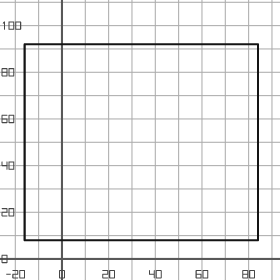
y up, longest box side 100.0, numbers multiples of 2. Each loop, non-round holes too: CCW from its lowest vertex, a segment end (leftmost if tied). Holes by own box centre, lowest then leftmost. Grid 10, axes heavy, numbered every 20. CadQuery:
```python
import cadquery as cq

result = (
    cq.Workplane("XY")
    .moveTo(-16.0, 8.0)
    .lineTo(84.0, 8.0)
    .lineTo(84.0, 92.0)
    .lineTo(-16.0, 92.0)
    .close()
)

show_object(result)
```